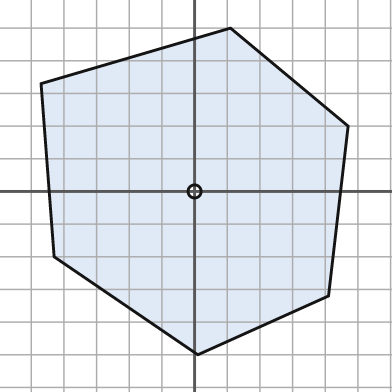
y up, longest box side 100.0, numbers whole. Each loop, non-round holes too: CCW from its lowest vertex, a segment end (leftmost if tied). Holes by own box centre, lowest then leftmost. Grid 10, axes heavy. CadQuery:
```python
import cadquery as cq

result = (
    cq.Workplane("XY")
    .moveTo(1.0, -50.0)
    .lineTo(41.0, -32.0)
    .lineTo(47.0, 20.0)
    .lineTo(11.0, 50.0)
    .lineTo(-47.0, 33.0)
    .lineTo(-43.0, -20.0)
    .close()
    .moveTo(0.0, 0.0)
    .circle(2.0)
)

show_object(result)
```